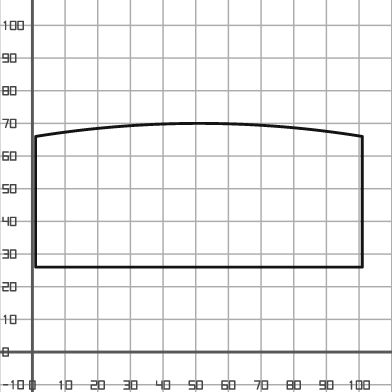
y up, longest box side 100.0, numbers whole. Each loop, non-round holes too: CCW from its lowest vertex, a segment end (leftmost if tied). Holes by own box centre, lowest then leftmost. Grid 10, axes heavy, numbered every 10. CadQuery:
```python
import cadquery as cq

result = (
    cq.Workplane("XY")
    .moveTo(1.0, 26.0)
    .lineTo(101.0, 26.0)
    .lineTo(101.0, 66.0)
    .threePointArc((51.0, 70.0), (1.0, 66.0))
    .close()
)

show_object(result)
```